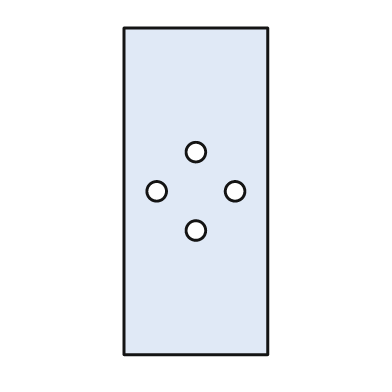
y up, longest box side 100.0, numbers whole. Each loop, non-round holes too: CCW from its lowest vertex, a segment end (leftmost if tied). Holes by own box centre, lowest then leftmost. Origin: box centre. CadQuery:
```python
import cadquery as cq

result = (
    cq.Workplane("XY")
    .moveTo(-22.0, -50.0)
    .lineTo(22.0, -50.0)
    .lineTo(22.0, 50.0)
    .lineTo(-22.0, 50.0)
    .close()
    .moveTo(0.0, -12.0)
    .circle(3.0)
    .moveTo(-12.0, 0.0)
    .circle(3.0)
    .moveTo(12.0, 0.0)
    .circle(3.0)
    .moveTo(0.0, 12.0)
    .circle(3.0)
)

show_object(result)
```